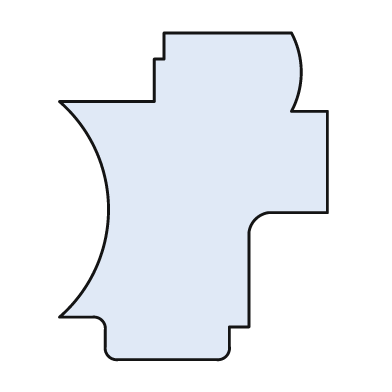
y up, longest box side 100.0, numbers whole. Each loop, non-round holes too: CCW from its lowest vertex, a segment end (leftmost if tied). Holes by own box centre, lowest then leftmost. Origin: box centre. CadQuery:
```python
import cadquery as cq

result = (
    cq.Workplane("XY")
    .moveTo(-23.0, -50.0)
    .lineTo(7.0, -50.0)
    .threePointArc((10.0, -49.0), (11.0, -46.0))
    .lineTo(11.0, -40.0)
    .lineTo(17.0, -40.0)
    .lineTo(17.0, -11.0)
    .threePointArc((19.0, -7.0), (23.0, -5.0))
    .lineTo(41.0, -5.0)
    .lineTo(41.0, 26.0)
    .lineTo(30.0, 26.0)
    .threePointArc((33.0, 38.0), (30.0, 50.0))
    .lineTo(-9.0, 50.0)
    .lineTo(-9.0, 42.0)
    .lineTo(-12.0, 42.0)
    .lineTo(-12.0, 29.0)
    .lineTo(-41.0, 29.0)
    .threePointArc((-26.0, -4.0), (-41.0, -37.0))
    .lineTo(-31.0, -37.0)
    .threePointArc((-28.0, -38.0), (-27.0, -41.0))
    .lineTo(-27.0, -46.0)
    .threePointArc((-26.0, -49.0), (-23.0, -50.0))
    .close()
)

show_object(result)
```